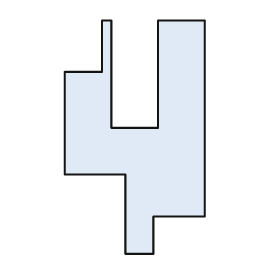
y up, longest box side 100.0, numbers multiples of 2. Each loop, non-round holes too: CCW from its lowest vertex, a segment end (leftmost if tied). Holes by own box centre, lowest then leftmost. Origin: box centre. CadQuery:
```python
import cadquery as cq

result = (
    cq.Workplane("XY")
    .moveTo(-4.0, -50.0)
    .lineTo(8.0, -50.0)
    .lineTo(8.0, -34.0)
    .lineTo(30.0, -34.0)
    .lineTo(30.0, 50.0)
    .lineTo(10.0, 50.0)
    .lineTo(10.0, 4.0)
    .lineTo(-10.0, 4.0)
    .lineTo(-10.0, 50.0)
    .lineTo(-14.0, 50.0)
    .lineTo(-14.0, 28.0)
    .lineTo(-30.0, 28.0)
    .lineTo(-30.0, -16.0)
    .lineTo(-4.0, -16.0)
    .close()
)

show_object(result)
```